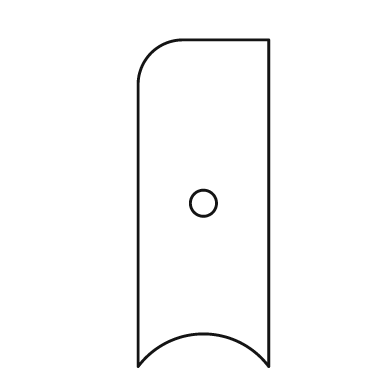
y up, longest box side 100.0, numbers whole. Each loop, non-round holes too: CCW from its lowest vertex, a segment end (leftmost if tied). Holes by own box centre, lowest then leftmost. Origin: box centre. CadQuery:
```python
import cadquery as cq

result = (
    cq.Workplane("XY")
    .moveTo(-20.0, -50.0)
    .threePointArc((0.0, -40.0), (20.0, -50.0))
    .lineTo(20.0, 50.0)
    .lineTo(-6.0, 50.0)
    .threePointArc((-16.0, 46.0), (-20.0, 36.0))
    .close()
    .moveTo(0.0, 0.0)
    .circle(4.0)
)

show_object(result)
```